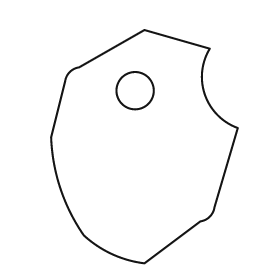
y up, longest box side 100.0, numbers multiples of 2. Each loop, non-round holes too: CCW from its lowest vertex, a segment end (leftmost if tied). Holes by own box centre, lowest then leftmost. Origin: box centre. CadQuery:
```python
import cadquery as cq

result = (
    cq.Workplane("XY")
    .moveTo(0.0, -50.0)
    .lineTo(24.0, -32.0)
    .threePointArc((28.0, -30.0), (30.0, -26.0))
    .lineTo(40.0, 8.0)
    .threePointArc((26.0, 22.0), (28.0, 42.0))
    .lineTo(0.0, 50.0)
    .lineTo(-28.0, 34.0)
    .threePointArc((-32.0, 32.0), (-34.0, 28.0))
    .lineTo(-40.0, 4.0)
    .threePointArc((-36.0, -18.0), (-26.0, -38.0))
    .threePointArc((-14.0, -46.0), (0.0, -50.0))
    .close()
    .moveTo(-4.0, 24.0)
    .circle(8.0)
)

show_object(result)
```